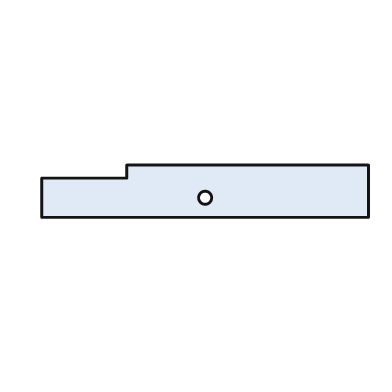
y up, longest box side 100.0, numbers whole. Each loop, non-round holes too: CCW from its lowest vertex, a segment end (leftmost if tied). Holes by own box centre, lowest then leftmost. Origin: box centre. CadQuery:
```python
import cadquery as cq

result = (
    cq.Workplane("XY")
    .moveTo(-50.0, -8.0)
    .lineTo(50.0, -8.0)
    .lineTo(50.0, 8.0)
    .lineTo(-24.0, 8.0)
    .lineTo(-24.0, 4.0)
    .lineTo(-50.0, 4.0)
    .close()
    .moveTo(0.0, -2.0)
    .circle(2.0)
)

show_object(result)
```